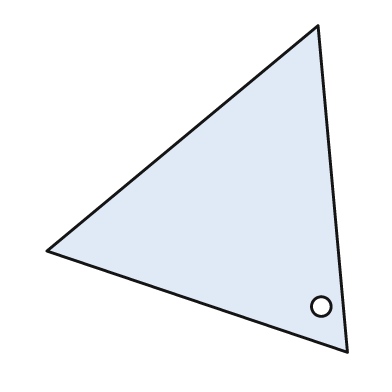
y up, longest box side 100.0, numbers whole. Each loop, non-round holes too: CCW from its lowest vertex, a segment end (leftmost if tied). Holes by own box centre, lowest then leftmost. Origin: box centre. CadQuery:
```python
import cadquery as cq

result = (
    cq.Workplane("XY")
    .moveTo(46.0, -50.0)
    .lineTo(37.0, 50.0)
    .lineTo(-46.0, -19.0)
    .close()
    .moveTo(38.0, -36.0)
    .circle(3.0)
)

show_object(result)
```